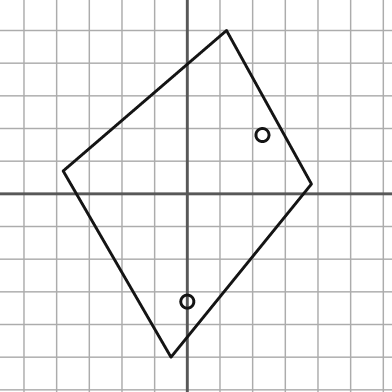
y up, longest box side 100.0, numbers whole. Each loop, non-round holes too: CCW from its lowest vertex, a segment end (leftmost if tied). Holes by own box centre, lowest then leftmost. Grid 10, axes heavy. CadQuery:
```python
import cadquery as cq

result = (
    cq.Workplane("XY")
    .moveTo(-5.0, -50.0)
    .lineTo(38.0, 3.0)
    .lineTo(12.0, 50.0)
    .lineTo(-38.0, 7.0)
    .close()
    .moveTo(0.0, -33.0)
    .circle(2.0)
    .moveTo(23.0, 18.0)
    .circle(2.0)
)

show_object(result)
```